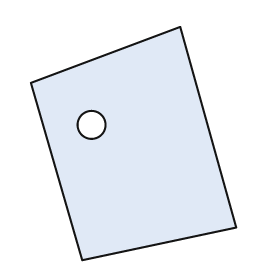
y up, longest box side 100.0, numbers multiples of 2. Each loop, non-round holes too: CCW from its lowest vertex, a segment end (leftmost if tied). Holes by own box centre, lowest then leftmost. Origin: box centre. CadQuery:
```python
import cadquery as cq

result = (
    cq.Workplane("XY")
    .moveTo(-22.0, -50.0)
    .lineTo(44.0, -36.0)
    .lineTo(20.0, 50.0)
    .lineTo(-44.0, 26.0)
    .close()
    .moveTo(-18.0, 8.0)
    .circle(6.0)
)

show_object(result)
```